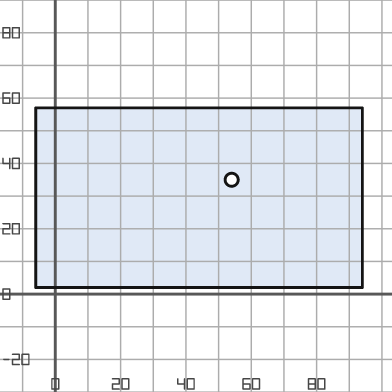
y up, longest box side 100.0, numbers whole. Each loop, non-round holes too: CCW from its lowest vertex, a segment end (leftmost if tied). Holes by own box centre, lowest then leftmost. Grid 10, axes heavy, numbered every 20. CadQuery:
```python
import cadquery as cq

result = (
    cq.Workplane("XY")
    .moveTo(-6.0, 2.0)
    .lineTo(94.0, 2.0)
    .lineTo(94.0, 57.0)
    .lineTo(-6.0, 57.0)
    .close()
    .moveTo(54.0, 35.0)
    .circle(2.0)
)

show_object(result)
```